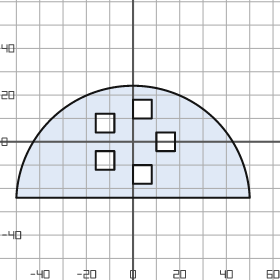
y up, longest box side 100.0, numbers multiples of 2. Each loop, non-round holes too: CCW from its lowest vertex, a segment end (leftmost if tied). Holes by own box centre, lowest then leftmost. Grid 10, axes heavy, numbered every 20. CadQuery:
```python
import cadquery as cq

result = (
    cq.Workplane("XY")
    .moveTo(-50.0, -24.0)
    .lineTo(50.0, -24.0)
    .threePointArc((0.0, 24.0), (-50.0, -24.0))
    .close()
    .moveTo(0.0, -18.0)
    .lineTo(8.0, -18.0)
    .lineTo(8.0, -10.0)
    .lineTo(0.0, -10.0)
    .close()
    .moveTo(-16.0, -12.0)
    .lineTo(-8.0, -12.0)
    .lineTo(-8.0, -4.0)
    .lineTo(-16.0, -4.0)
    .close()
    .moveTo(10.0, -4.0)
    .lineTo(18.0, -4.0)
    .lineTo(18.0, 4.0)
    .lineTo(10.0, 4.0)
    .close()
    .moveTo(-16.0, 4.0)
    .lineTo(-8.0, 4.0)
    .lineTo(-8.0, 12.0)
    .lineTo(-16.0, 12.0)
    .close()
    .moveTo(0.0, 10.0)
    .lineTo(8.0, 10.0)
    .lineTo(8.0, 18.0)
    .lineTo(0.0, 18.0)
    .close()
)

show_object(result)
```